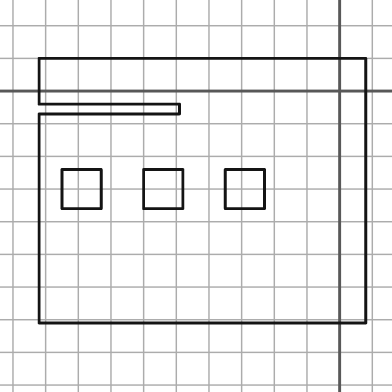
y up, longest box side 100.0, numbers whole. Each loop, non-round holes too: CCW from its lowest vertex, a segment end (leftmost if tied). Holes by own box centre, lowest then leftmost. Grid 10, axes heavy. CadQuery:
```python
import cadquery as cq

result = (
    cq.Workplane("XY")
    .moveTo(-92.0, -71.0)
    .lineTo(8.0, -71.0)
    .lineTo(8.0, 10.0)
    .lineTo(-92.0, 10.0)
    .lineTo(-92.0, -4.0)
    .lineTo(-49.0, -4.0)
    .lineTo(-49.0, -7.0)
    .lineTo(-92.0, -7.0)
    .close()
    .moveTo(-85.0, -36.0)
    .lineTo(-73.0, -36.0)
    .lineTo(-73.0, -24.0)
    .lineTo(-85.0, -24.0)
    .close()
    .moveTo(-60.0, -36.0)
    .lineTo(-48.0, -36.0)
    .lineTo(-48.0, -24.0)
    .lineTo(-60.0, -24.0)
    .close()
    .moveTo(-35.0, -36.0)
    .lineTo(-23.0, -36.0)
    .lineTo(-23.0, -24.0)
    .lineTo(-35.0, -24.0)
    .close()
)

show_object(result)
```